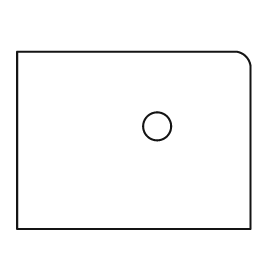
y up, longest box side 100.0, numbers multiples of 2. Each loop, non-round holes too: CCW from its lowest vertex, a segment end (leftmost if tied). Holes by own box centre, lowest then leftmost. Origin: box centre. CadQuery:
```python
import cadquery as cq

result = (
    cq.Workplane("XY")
    .moveTo(-50.0, -38.0)
    .lineTo(50.0, -38.0)
    .lineTo(50.0, 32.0)
    .threePointArc((48.0, 36.0), (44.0, 38.0))
    .lineTo(-50.0, 38.0)
    .close()
    .moveTo(10.0, 6.0)
    .circle(6.0)
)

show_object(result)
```